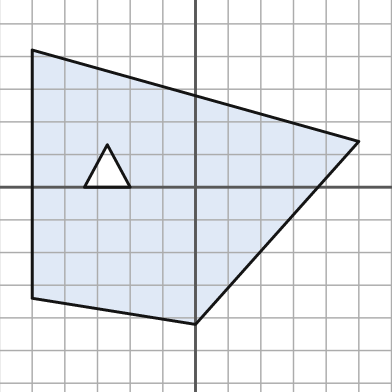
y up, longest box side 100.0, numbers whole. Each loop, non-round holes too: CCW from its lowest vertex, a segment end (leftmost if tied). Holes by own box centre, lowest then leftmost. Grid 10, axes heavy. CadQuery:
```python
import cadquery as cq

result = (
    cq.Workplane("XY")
    .moveTo(0.0, -42.0)
    .lineTo(50.0, 14.0)
    .lineTo(-50.0, 42.0)
    .lineTo(-50.0, -34.0)
    .close()
    .moveTo(-34.0, 0.0)
    .lineTo(-20.0, 0.0)
    .lineTo(-27.0, 13.0)
    .close()
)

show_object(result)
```